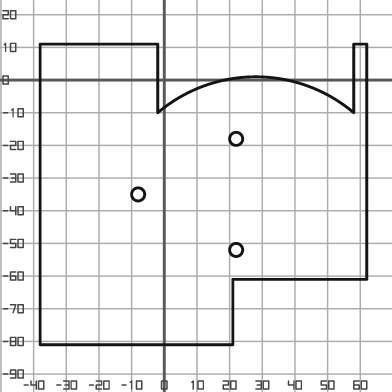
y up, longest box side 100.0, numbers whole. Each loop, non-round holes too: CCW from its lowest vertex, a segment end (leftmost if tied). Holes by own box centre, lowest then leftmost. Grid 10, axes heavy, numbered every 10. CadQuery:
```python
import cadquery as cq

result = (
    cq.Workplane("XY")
    .moveTo(-38.0, -81.0)
    .lineTo(21.0, -81.0)
    .lineTo(21.0, -61.0)
    .lineTo(62.0, -61.0)
    .lineTo(62.0, 11.0)
    .lineTo(58.0, 11.0)
    .lineTo(58.0, -10.0)
    .threePointArc((28.0, 1.0), (-2.0, -10.0))
    .lineTo(-2.0, 11.0)
    .lineTo(-38.0, 11.0)
    .close()
    .moveTo(22.0, -52.0)
    .circle(2.0)
    .moveTo(-8.0, -35.0)
    .circle(2.0)
    .moveTo(22.0, -18.0)
    .circle(2.0)
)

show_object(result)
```